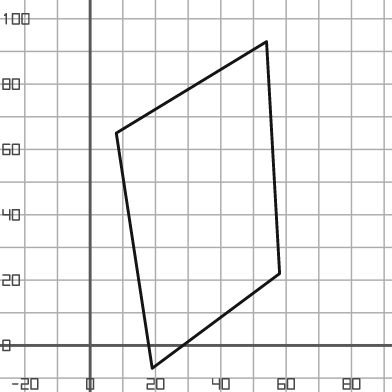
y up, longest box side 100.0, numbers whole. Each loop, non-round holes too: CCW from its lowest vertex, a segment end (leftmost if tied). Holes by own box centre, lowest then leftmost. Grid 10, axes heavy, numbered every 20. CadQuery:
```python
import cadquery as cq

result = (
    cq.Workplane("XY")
    .moveTo(19.0, -7.0)
    .lineTo(58.0, 22.0)
    .lineTo(54.0, 93.0)
    .lineTo(8.0, 65.0)
    .close()
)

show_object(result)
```